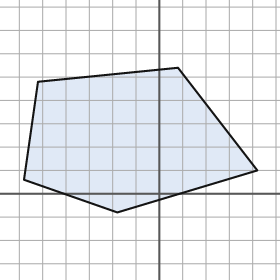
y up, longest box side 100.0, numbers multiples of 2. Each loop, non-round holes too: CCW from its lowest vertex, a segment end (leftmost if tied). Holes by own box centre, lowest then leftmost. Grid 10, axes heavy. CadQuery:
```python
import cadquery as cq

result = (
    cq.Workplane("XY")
    .moveTo(-18.0, -8.0)
    .lineTo(42.0, 10.0)
    .lineTo(8.0, 54.0)
    .lineTo(-52.0, 48.0)
    .lineTo(-58.0, 6.0)
    .close()
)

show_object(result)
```